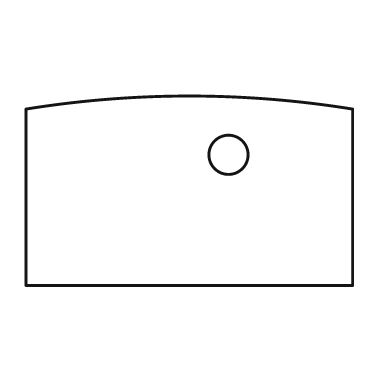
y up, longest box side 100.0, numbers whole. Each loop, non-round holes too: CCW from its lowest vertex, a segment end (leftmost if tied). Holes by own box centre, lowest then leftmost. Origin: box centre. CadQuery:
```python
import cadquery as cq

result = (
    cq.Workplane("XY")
    .moveTo(-50.0, -29.0)
    .lineTo(50.0, -29.0)
    .lineTo(50.0, 25.0)
    .threePointArc((0.0, 29.0), (-50.0, 25.0))
    .close()
    .moveTo(12.0, 11.0)
    .circle(6.0)
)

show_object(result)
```